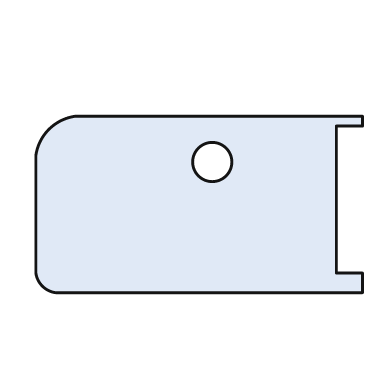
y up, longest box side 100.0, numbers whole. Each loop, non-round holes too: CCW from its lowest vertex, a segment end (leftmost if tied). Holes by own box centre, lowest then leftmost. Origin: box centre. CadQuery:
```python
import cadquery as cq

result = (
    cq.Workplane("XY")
    .moveTo(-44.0, -27.0)
    .lineTo(50.0, -27.0)
    .lineTo(50.0, -21.0)
    .lineTo(42.0, -21.0)
    .lineTo(42.0, 24.0)
    .lineTo(50.0, 24.0)
    .lineTo(50.0, 27.0)
    .lineTo(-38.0, 27.0)
    .threePointArc((-46.0, 23.0), (-50.0, 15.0))
    .lineTo(-50.0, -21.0)
    .threePointArc((-48.0, -25.0), (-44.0, -27.0))
    .close()
    .moveTo(4.0, 13.0)
    .circle(6.0)
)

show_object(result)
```